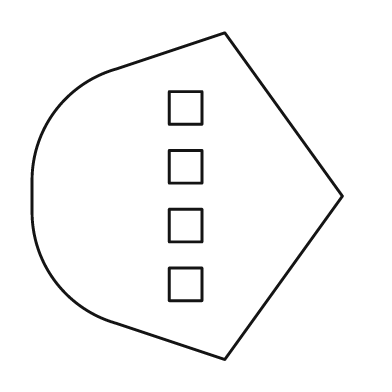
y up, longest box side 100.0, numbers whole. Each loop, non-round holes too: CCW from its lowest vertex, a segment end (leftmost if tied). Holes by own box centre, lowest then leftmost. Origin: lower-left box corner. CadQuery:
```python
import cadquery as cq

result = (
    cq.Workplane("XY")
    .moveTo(59.0, 0.0)
    .lineTo(95.0, 50.0)
    .lineTo(59.0, 100.0)
    .lineTo(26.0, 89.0)
    .threePointArc((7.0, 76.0), (0.0, 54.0))
    .lineTo(0.0, 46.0)
    .threePointArc((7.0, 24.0), (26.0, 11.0))
    .close()
    .moveTo(42.0, 18.0)
    .lineTo(52.0, 18.0)
    .lineTo(52.0, 28.0)
    .lineTo(42.0, 28.0)
    .close()
    .moveTo(42.0, 36.0)
    .lineTo(52.0, 36.0)
    .lineTo(52.0, 46.0)
    .lineTo(42.0, 46.0)
    .close()
    .moveTo(42.0, 54.0)
    .lineTo(52.0, 54.0)
    .lineTo(52.0, 64.0)
    .lineTo(42.0, 64.0)
    .close()
    .moveTo(42.0, 72.0)
    .lineTo(52.0, 72.0)
    .lineTo(52.0, 82.0)
    .lineTo(42.0, 82.0)
    .close()
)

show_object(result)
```